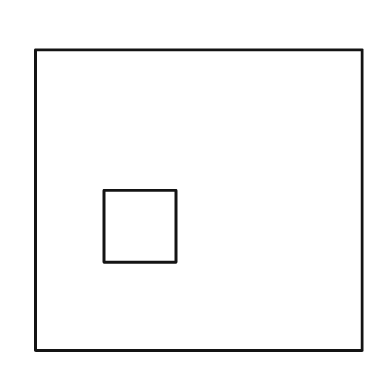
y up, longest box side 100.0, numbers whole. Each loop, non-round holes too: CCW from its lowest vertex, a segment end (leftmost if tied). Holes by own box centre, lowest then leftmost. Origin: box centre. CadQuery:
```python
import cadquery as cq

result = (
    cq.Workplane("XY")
    .moveTo(-50.0, -46.0)
    .lineTo(50.0, -46.0)
    .lineTo(50.0, 46.0)
    .lineTo(-50.0, 46.0)
    .close()
    .moveTo(-29.0, -19.0)
    .lineTo(-7.0, -19.0)
    .lineTo(-7.0, 3.0)
    .lineTo(-29.0, 3.0)
    .close()
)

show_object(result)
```